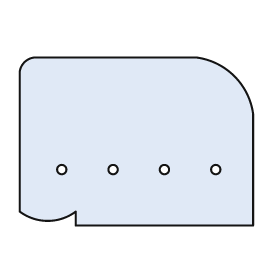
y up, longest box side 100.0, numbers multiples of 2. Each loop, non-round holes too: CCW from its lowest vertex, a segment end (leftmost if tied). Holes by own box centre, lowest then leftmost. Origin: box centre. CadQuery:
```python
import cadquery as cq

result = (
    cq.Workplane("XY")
    .moveTo(-26.0, -36.0)
    .lineTo(50.0, -36.0)
    .lineTo(50.0, 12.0)
    .threePointArc((42.0, 28.0), (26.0, 36.0))
    .lineTo(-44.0, 36.0)
    .threePointArc((-48.0, 34.0), (-50.0, 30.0))
    .lineTo(-50.0, -30.0)
    .threePointArc((-38.0, -34.0), (-26.0, -30.0))
    .close()
    .moveTo(-32.0, -12.0)
    .circle(2.0)
    .moveTo(-10.0, -12.0)
    .circle(2.0)
    .moveTo(12.0, -12.0)
    .circle(2.0)
    .moveTo(34.0, -12.0)
    .circle(2.0)
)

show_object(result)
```